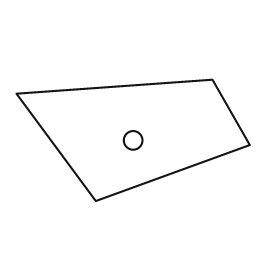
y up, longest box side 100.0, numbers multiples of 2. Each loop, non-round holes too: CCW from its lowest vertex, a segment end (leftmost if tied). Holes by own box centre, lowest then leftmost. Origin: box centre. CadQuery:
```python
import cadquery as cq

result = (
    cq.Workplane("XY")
    .moveTo(-16.0, -26.0)
    .lineTo(50.0, -2.0)
    .lineTo(34.0, 26.0)
    .lineTo(-50.0, 20.0)
    .close()
    .moveTo(0.0, 0.0)
    .circle(4.0)
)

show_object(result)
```